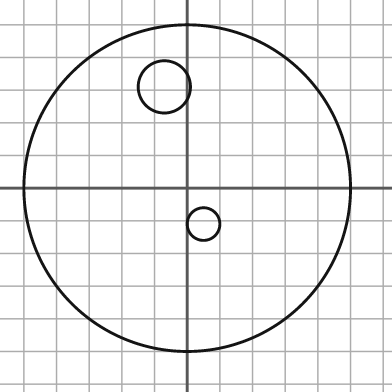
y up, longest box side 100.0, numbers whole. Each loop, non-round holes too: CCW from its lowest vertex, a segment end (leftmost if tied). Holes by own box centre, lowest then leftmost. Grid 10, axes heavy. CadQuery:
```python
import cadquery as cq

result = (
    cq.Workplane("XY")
    .moveTo(0.0, 0.0)
    .circle(50.0)
    .moveTo(5.0, -11.0)
    .circle(5.0)
    .moveTo(-7.0, 31.0)
    .circle(8.0)
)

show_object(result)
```